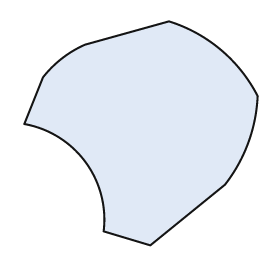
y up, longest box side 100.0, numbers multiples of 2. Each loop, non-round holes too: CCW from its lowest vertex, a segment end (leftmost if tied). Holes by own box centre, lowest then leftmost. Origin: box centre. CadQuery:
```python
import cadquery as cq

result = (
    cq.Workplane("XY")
    .moveTo(4.0, -48.0)
    .lineTo(36.0, -22.0)
    .threePointArc((46.0, -4.0), (50.0, 16.0))
    .threePointArc((34.0, 36.0), (12.0, 48.0))
    .lineTo(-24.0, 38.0)
    .threePointArc((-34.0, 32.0), (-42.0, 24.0))
    .lineTo(-50.0, 4.0)
    .threePointArc((-24.0, -12.0), (-16.0, -42.0))
    .close()
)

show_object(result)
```